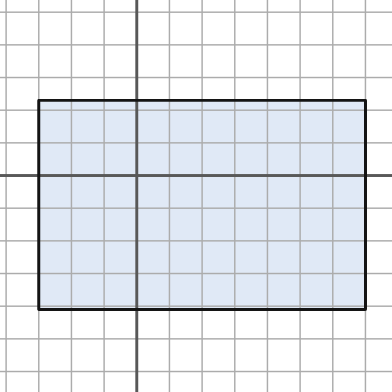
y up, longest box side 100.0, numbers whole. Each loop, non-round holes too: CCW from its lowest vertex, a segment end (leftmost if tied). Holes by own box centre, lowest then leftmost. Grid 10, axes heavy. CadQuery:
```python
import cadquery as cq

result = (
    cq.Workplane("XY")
    .moveTo(-30.0, -41.0)
    .lineTo(70.0, -41.0)
    .lineTo(70.0, 23.0)
    .lineTo(-30.0, 23.0)
    .close()
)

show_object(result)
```